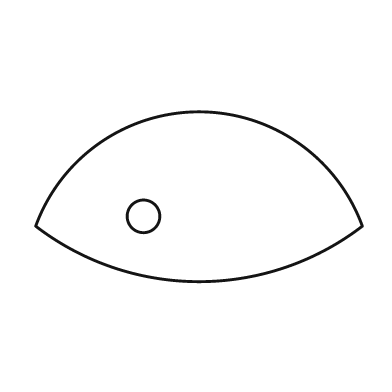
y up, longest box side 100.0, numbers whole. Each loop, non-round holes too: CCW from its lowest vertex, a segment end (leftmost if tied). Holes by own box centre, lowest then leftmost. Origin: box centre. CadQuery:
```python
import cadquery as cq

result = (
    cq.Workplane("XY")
    .moveTo(-50.0, -9.0)
    .threePointArc((0.0, -26.0), (50.0, -9.0))
    .threePointArc((0.0, 26.0), (-50.0, -9.0))
    .close()
    .moveTo(-17.0, -6.0)
    .circle(5.0)
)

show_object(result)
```